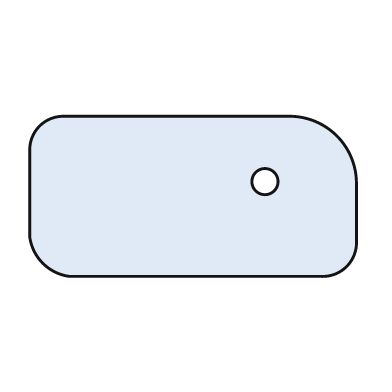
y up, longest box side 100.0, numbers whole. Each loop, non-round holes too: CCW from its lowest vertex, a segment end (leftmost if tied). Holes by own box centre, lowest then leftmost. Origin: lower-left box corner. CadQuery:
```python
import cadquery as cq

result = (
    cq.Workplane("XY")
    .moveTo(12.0, 0.0)
    .lineTo(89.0, 0.0)
    .threePointArc((97.0, 3.0), (100.0, 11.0))
    .lineTo(100.0, 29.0)
    .threePointArc((94.0, 43.0), (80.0, 49.0))
    .lineTo(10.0, 49.0)
    .threePointArc((3.0, 46.0), (0.0, 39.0))
    .lineTo(0.0, 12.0)
    .threePointArc((4.0, 4.0), (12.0, 0.0))
    .close()
    .moveTo(72.0, 29.0)
    .circle(4.0)
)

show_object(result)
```